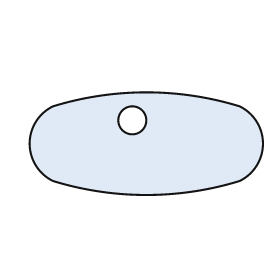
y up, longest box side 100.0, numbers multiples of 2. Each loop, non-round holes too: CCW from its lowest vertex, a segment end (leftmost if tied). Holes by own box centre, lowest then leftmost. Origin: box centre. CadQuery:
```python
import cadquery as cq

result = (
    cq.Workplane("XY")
    .moveTo(-40.0, -16.0)
    .threePointArc((0.0, -22.0), (40.0, -16.0))
    .threePointArc((50.0, 0.0), (40.0, 16.0))
    .threePointArc((0.0, 22.0), (-40.0, 16.0))
    .threePointArc((-50.0, 0.0), (-40.0, -16.0))
    .close()
    .moveTo(-6.0, 10.0)
    .circle(6.0)
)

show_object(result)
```